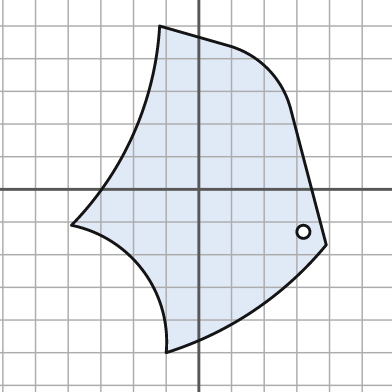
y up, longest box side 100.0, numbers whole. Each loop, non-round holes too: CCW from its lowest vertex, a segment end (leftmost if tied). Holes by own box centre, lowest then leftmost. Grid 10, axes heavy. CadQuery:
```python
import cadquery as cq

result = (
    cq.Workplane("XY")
    .moveTo(-10.0, -50.0)
    .threePointArc((17.0, -37.0), (39.0, -17.0))
    .lineTo(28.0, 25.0)
    .threePointArc((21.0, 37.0), (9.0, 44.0))
    .lineTo(-12.0, 50.0)
    .threePointArc((-20.0, 17.0), (-39.0, -11.0))
    .threePointArc((-17.0, -25.0), (-10.0, -50.0))
    .close()
    .moveTo(32.0, -13.0)
    .circle(2.0)
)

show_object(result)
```